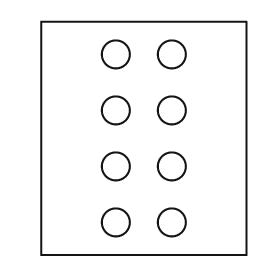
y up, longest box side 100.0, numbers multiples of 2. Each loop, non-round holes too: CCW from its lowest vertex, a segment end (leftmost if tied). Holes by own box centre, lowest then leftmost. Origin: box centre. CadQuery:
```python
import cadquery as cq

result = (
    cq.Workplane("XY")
    .moveTo(-44.0, -50.0)
    .lineTo(44.0, -50.0)
    .lineTo(44.0, 50.0)
    .lineTo(-44.0, 50.0)
    .close()
    .moveTo(-12.0, -36.0)
    .circle(6.0)
    .moveTo(12.0, -36.0)
    .circle(6.0)
    .moveTo(-12.0, -12.0)
    .circle(6.0)
    .moveTo(12.0, -12.0)
    .circle(6.0)
    .moveTo(-12.0, 12.0)
    .circle(6.0)
    .moveTo(12.0, 12.0)
    .circle(6.0)
    .moveTo(-12.0, 36.0)
    .circle(6.0)
    .moveTo(12.0, 36.0)
    .circle(6.0)
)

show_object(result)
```